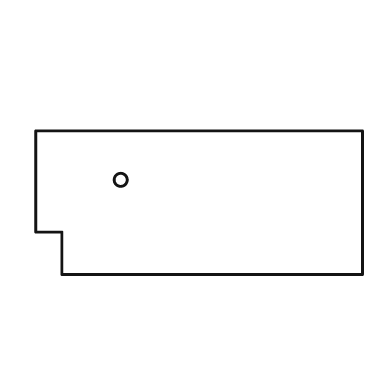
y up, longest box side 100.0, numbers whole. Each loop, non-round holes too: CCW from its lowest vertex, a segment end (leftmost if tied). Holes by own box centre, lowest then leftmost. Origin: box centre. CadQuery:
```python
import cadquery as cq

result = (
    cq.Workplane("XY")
    .moveTo(-42.0, -22.0)
    .lineTo(50.0, -22.0)
    .lineTo(50.0, 22.0)
    .lineTo(-50.0, 22.0)
    .lineTo(-50.0, -9.0)
    .lineTo(-42.0, -9.0)
    .close()
    .moveTo(-24.0, 7.0)
    .circle(2.0)
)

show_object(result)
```